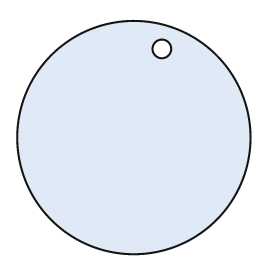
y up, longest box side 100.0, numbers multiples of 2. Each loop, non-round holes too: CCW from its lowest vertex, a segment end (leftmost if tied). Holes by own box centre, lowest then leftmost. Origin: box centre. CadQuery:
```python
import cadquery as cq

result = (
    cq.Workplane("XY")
    .moveTo(0.0, 0.0)
    .circle(50.0)
    .moveTo(12.0, 38.0)
    .circle(4.0)
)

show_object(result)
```